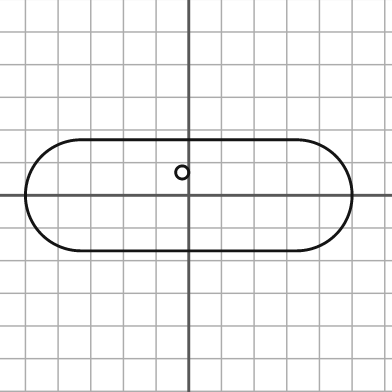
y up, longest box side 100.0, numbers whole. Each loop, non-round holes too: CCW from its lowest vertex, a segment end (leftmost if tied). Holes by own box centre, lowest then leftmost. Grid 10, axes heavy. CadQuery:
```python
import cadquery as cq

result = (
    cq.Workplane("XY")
    .moveTo(-33.0, -17.0)
    .lineTo(33.0, -17.0)
    .threePointArc((50.0, 0.0), (33.0, 17.0))
    .lineTo(-33.0, 17.0)
    .threePointArc((-50.0, 0.0), (-33.0, -17.0))
    .close()
    .moveTo(-2.0, 7.0)
    .circle(2.0)
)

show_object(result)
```